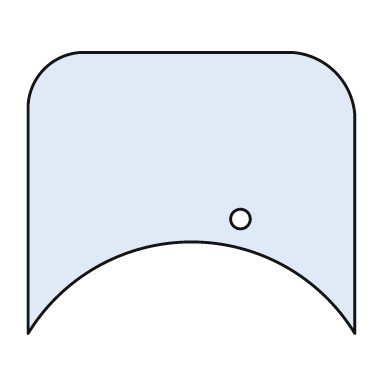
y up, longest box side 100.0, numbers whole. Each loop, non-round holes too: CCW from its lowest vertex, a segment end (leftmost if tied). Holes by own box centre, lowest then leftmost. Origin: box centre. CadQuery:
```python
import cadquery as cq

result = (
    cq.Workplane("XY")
    .moveTo(-50.0, -43.0)
    .threePointArc((0.0, -15.0), (50.0, -43.0))
    .lineTo(50.0, 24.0)
    .threePointArc((44.0, 37.0), (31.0, 43.0))
    .lineTo(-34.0, 43.0)
    .threePointArc((-45.0, 38.0), (-50.0, 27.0))
    .close()
    .moveTo(15.0, -8.0)
    .circle(3.0)
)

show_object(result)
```